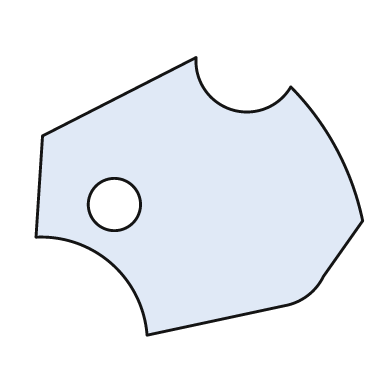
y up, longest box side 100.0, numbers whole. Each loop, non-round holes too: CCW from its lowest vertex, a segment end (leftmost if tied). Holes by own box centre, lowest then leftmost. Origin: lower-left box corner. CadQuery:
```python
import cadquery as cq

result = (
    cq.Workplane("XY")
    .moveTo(34.0, 0.0)
    .lineTo(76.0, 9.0)
    .threePointArc((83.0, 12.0), (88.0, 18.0))
    .lineTo(100.0, 35.0)
    .threePointArc((92.0, 57.0), (78.0, 76.0))
    .threePointArc((60.0, 69.0), (49.0, 85.0))
    .lineTo(2.0, 61.0)
    .lineTo(0.0, 30.0)
    .threePointArc((23.0, 22.0), (34.0, 0.0))
    .close()
    .moveTo(24.0, 40.0)
    .circle(8.0)
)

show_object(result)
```